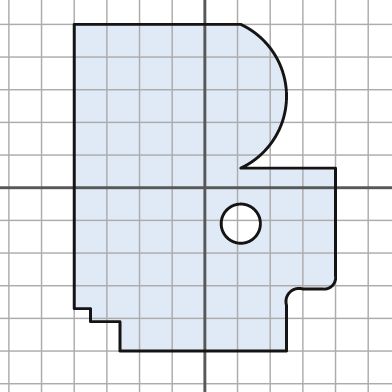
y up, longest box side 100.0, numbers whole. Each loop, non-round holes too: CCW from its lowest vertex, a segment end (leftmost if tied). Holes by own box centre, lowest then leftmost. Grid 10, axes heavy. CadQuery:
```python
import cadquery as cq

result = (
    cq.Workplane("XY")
    .moveTo(-26.0, -50.0)
    .lineTo(25.0, -50.0)
    .lineTo(25.0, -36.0)
    .threePointArc((26.0, -32.0), (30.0, -31.0))
    .lineTo(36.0, -31.0)
    .threePointArc((39.0, -30.0), (40.0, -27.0))
    .lineTo(40.0, 6.0)
    .lineTo(11.0, 6.0)
    .threePointArc((25.0, 28.0), (11.0, 50.0))
    .lineTo(-40.0, 50.0)
    .lineTo(-40.0, -37.0)
    .lineTo(-35.0, -37.0)
    .lineTo(-35.0, -41.0)
    .lineTo(-26.0, -41.0)
    .close()
    .moveTo(11.0, -11.0)
    .circle(6.0)
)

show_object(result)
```